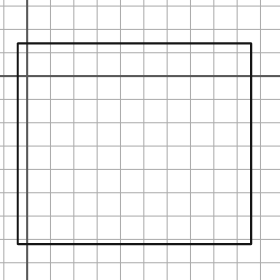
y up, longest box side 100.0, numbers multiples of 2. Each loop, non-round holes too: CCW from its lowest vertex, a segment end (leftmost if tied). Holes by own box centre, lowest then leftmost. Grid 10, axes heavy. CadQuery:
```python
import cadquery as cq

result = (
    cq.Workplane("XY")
    .moveTo(-4.0, -72.0)
    .lineTo(96.0, -72.0)
    .lineTo(96.0, 14.0)
    .lineTo(-4.0, 14.0)
    .close()
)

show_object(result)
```